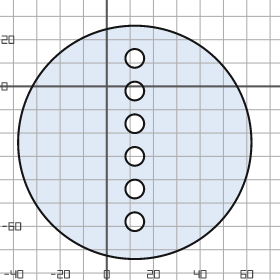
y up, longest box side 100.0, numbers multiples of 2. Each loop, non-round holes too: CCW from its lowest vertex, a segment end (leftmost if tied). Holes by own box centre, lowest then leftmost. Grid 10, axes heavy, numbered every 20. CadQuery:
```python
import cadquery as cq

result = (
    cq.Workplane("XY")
    .moveTo(12.0, -24.0)
    .circle(50.0)
    .moveTo(12.0, -58.0)
    .circle(4.0)
    .moveTo(12.0, -44.0)
    .circle(4.0)
    .moveTo(12.0, -30.0)
    .circle(4.0)
    .moveTo(12.0, -16.0)
    .circle(4.0)
    .moveTo(12.0, -2.0)
    .circle(4.0)
    .moveTo(12.0, 12.0)
    .circle(4.0)
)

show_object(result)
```